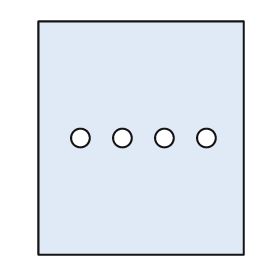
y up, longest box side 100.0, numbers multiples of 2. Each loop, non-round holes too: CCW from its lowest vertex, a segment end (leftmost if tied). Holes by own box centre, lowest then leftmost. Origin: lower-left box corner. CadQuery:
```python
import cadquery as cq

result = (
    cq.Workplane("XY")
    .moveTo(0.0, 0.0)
    .lineTo(88.0, 0.0)
    .lineTo(88.0, 100.0)
    .lineTo(0.0, 100.0)
    .close()
    .moveTo(18.0, 50.0)
    .circle(4.0)
    .moveTo(36.0, 50.0)
    .circle(4.0)
    .moveTo(54.0, 50.0)
    .circle(4.0)
    .moveTo(72.0, 50.0)
    .circle(4.0)
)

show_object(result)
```